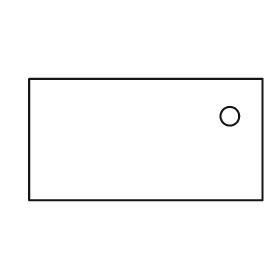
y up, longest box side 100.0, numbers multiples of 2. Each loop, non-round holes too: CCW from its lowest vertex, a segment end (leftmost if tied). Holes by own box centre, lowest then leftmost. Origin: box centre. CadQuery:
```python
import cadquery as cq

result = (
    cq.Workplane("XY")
    .moveTo(-50.0, -26.0)
    .lineTo(50.0, -26.0)
    .lineTo(50.0, 26.0)
    .lineTo(-50.0, 26.0)
    .close()
    .moveTo(36.0, 10.0)
    .circle(4.0)
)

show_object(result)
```